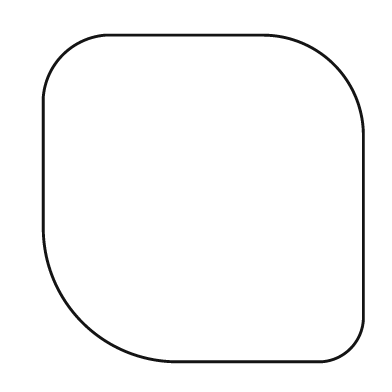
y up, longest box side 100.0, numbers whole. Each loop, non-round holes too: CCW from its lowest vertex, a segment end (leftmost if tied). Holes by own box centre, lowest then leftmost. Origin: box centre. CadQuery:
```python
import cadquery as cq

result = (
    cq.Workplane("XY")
    .moveTo(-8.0, -50.0)
    .lineTo(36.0, -50.0)
    .threePointArc((45.0, -46.0), (49.0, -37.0))
    .lineTo(49.0, 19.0)
    .threePointArc((40.0, 41.0), (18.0, 50.0))
    .lineTo(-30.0, 50.0)
    .threePointArc((-43.0, 44.0), (-49.0, 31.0))
    .lineTo(-49.0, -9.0)
    .threePointArc((-37.0, -38.0), (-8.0, -50.0))
    .close()
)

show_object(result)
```